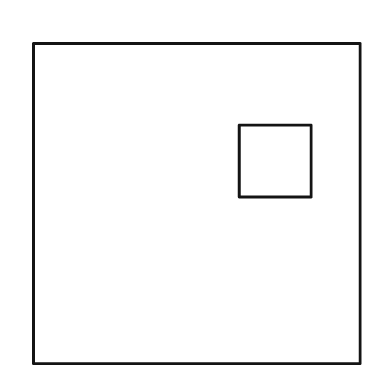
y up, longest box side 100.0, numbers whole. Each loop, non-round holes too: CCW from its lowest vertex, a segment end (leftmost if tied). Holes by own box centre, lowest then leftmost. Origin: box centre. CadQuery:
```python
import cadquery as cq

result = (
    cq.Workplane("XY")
    .moveTo(-50.0, -49.0)
    .lineTo(50.0, -49.0)
    .lineTo(50.0, 49.0)
    .lineTo(-50.0, 49.0)
    .close()
    .moveTo(13.0, 2.0)
    .lineTo(35.0, 2.0)
    .lineTo(35.0, 24.0)
    .lineTo(13.0, 24.0)
    .close()
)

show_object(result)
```